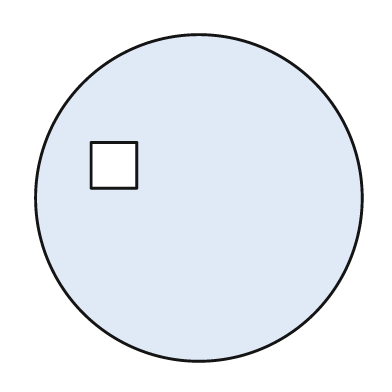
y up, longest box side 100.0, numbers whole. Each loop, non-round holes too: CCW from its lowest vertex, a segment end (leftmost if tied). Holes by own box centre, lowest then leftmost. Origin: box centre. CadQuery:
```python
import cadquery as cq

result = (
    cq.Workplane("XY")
    .moveTo(0.0, 0.0)
    .circle(50.0)
    .moveTo(-33.0, 3.0)
    .lineTo(-19.0, 3.0)
    .lineTo(-19.0, 17.0)
    .lineTo(-33.0, 17.0)
    .close()
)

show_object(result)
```